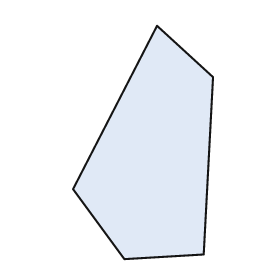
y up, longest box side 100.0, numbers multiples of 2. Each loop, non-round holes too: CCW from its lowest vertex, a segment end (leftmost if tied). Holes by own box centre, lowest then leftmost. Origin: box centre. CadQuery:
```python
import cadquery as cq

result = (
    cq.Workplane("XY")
    .moveTo(-8.0, -50.0)
    .lineTo(26.0, -48.0)
    .lineTo(30.0, 28.0)
    .lineTo(6.0, 50.0)
    .lineTo(-30.0, -20.0)
    .close()
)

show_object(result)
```